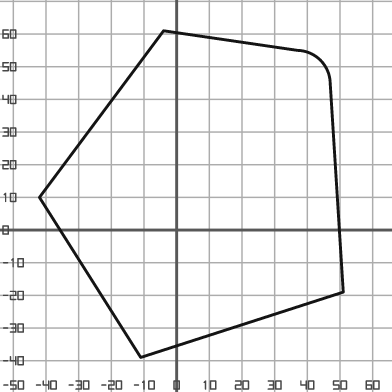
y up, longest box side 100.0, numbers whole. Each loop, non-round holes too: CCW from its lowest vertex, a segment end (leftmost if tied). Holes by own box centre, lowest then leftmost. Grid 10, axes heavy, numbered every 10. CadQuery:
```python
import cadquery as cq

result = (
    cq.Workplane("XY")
    .moveTo(-11.0, -39.0)
    .lineTo(51.0, -19.0)
    .lineTo(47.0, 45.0)
    .threePointArc((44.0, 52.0), (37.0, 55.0))
    .lineTo(-4.0, 61.0)
    .lineTo(-42.0, 10.0)
    .close()
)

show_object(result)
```